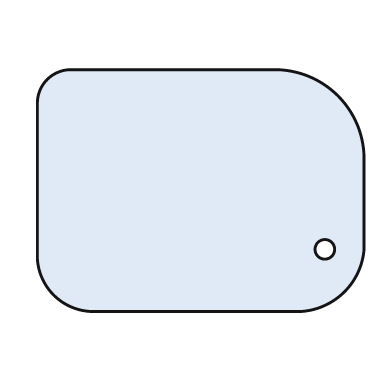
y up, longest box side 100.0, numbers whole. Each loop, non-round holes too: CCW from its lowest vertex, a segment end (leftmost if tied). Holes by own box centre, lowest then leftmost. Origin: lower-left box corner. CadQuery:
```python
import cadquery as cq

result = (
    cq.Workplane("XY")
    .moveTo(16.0, 0.0)
    .lineTo(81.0, 0.0)
    .threePointArc((94.0, 6.0), (100.0, 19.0))
    .lineTo(100.0, 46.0)
    .threePointArc((92.0, 66.0), (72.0, 74.0))
    .lineTo(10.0, 74.0)
    .threePointArc((3.0, 71.0), (0.0, 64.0))
    .lineTo(0.0, 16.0)
    .threePointArc((5.0, 5.0), (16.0, 0.0))
    .close()
    .moveTo(88.0, 19.0)
    .circle(3.0)
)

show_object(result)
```